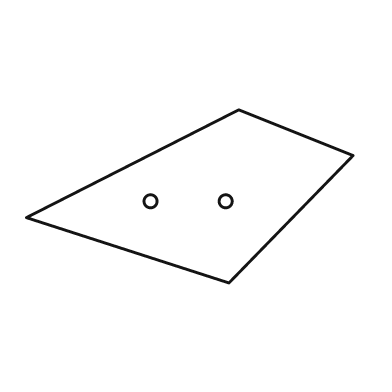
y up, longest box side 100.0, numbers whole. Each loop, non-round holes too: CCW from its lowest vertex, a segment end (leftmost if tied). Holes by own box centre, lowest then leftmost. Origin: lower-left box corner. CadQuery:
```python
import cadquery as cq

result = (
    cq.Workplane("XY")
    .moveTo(62.0, 0.0)
    .lineTo(100.0, 39.0)
    .lineTo(65.0, 53.0)
    .lineTo(0.0, 20.0)
    .close()
    .moveTo(38.0, 25.0)
    .circle(2.0)
    .moveTo(61.0, 25.0)
    .circle(2.0)
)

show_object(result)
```